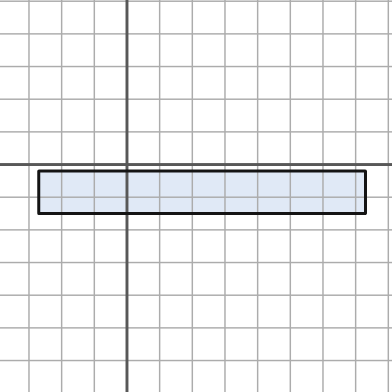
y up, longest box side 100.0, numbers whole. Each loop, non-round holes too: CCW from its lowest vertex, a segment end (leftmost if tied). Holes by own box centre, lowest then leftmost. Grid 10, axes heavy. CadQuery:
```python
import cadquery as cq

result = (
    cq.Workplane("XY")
    .moveTo(-27.0, -15.0)
    .lineTo(73.0, -15.0)
    .lineTo(73.0, -2.0)
    .lineTo(-27.0, -2.0)
    .close()
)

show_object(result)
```